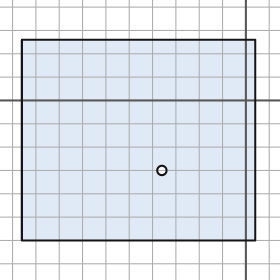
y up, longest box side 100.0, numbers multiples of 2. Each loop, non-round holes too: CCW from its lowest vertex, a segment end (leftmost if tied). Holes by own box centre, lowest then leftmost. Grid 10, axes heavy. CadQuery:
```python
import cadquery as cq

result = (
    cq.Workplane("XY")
    .moveTo(-96.0, -60.0)
    .lineTo(4.0, -60.0)
    .lineTo(4.0, 26.0)
    .lineTo(-96.0, 26.0)
    .close()
    .moveTo(-36.0, -30.0)
    .circle(2.0)
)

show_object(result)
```